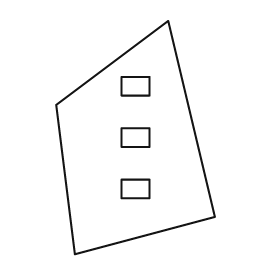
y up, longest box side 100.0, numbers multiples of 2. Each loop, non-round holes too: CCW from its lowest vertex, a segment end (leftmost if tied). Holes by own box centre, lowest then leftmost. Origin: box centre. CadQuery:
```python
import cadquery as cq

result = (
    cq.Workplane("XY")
    .moveTo(-26.0, -50.0)
    .lineTo(34.0, -34.0)
    .lineTo(14.0, 50.0)
    .lineTo(-34.0, 14.0)
    .close()
    .moveTo(-6.0, -26.0)
    .lineTo(6.0, -26.0)
    .lineTo(6.0, -18.0)
    .lineTo(-6.0, -18.0)
    .close()
    .moveTo(-6.0, -4.0)
    .lineTo(6.0, -4.0)
    .lineTo(6.0, 4.0)
    .lineTo(-6.0, 4.0)
    .close()
    .moveTo(-6.0, 18.0)
    .lineTo(6.0, 18.0)
    .lineTo(6.0, 26.0)
    .lineTo(-6.0, 26.0)
    .close()
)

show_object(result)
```